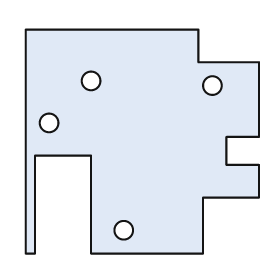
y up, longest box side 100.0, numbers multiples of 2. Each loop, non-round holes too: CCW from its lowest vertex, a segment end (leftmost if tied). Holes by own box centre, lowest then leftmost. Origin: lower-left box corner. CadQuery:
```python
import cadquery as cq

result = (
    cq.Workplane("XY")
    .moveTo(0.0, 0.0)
    .lineTo(4.0, 0.0)
    .lineTo(4.0, 42.0)
    .lineTo(28.0, 42.0)
    .lineTo(28.0, 0.0)
    .lineTo(76.0, 0.0)
    .lineTo(76.0, 24.0)
    .lineTo(100.0, 24.0)
    .lineTo(100.0, 38.0)
    .lineTo(86.0, 38.0)
    .lineTo(86.0, 50.0)
    .lineTo(100.0, 50.0)
    .lineTo(100.0, 82.0)
    .lineTo(74.0, 82.0)
    .lineTo(74.0, 96.0)
    .lineTo(0.0, 96.0)
    .close()
    .moveTo(42.0, 10.0)
    .circle(4.0)
    .moveTo(10.0, 56.0)
    .circle(4.0)
    .moveTo(80.0, 72.0)
    .circle(4.0)
    .moveTo(28.0, 74.0)
    .circle(4.0)
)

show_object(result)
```